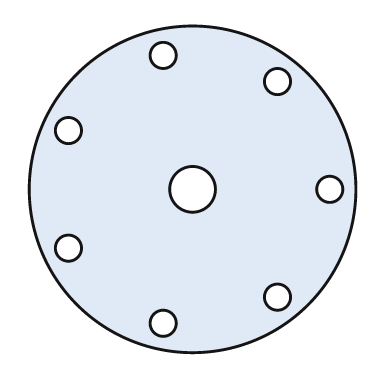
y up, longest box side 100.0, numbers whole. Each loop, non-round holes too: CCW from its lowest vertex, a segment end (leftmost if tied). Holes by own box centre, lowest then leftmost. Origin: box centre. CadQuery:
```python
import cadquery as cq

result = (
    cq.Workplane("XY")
    .moveTo(0.0, 0.0)
    .circle(50.0)
    .moveTo(-9.0, -41.0)
    .circle(4.0)
    .moveTo(26.0, -33.0)
    .circle(4.0)
    .moveTo(-38.0, -18.0)
    .circle(4.0)
    .moveTo(0.0, 0.0)
    .circle(7.0)
    .moveTo(42.0, 0.0)
    .circle(4.0)
    .moveTo(-38.0, 18.0)
    .circle(4.0)
    .moveTo(26.0, 33.0)
    .circle(4.0)
    .moveTo(-9.0, 41.0)
    .circle(4.0)
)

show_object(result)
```